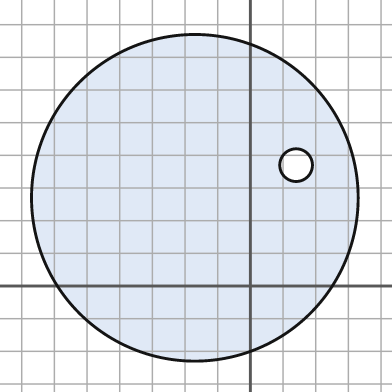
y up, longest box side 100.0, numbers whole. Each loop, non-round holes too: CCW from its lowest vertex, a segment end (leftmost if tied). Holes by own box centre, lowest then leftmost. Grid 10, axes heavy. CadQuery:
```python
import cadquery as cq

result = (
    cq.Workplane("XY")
    .moveTo(-17.0, 27.0)
    .circle(50.0)
    .moveTo(14.0, 37.0)
    .circle(5.0)
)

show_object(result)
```